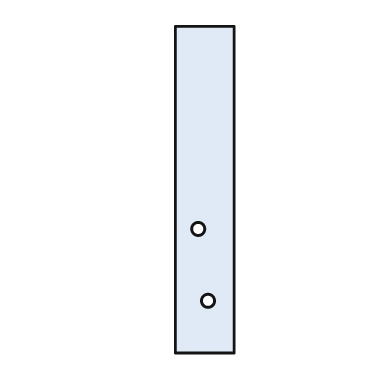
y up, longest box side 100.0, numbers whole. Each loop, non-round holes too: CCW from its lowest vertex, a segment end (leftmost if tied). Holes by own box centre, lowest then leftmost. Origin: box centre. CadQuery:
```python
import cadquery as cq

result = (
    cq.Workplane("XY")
    .moveTo(-9.0, -50.0)
    .lineTo(9.0, -50.0)
    .lineTo(9.0, 50.0)
    .lineTo(-9.0, 50.0)
    .close()
    .moveTo(1.0, -34.0)
    .circle(2.0)
    .moveTo(-2.0, -12.0)
    .circle(2.0)
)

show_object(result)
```